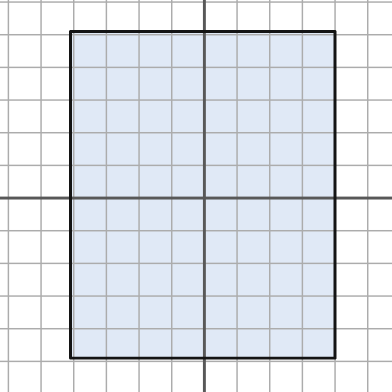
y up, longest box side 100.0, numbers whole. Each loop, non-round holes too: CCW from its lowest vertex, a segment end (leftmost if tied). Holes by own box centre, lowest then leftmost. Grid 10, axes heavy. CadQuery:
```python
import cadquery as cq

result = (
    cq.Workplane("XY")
    .moveTo(-41.0, -49.0)
    .lineTo(40.0, -49.0)
    .lineTo(40.0, 51.0)
    .lineTo(-41.0, 51.0)
    .close()
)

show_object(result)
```